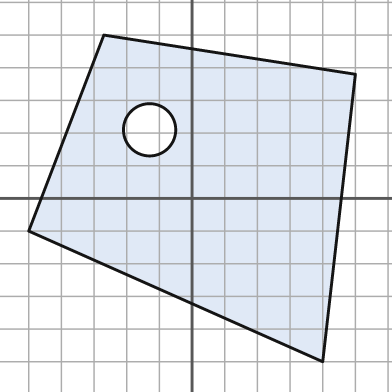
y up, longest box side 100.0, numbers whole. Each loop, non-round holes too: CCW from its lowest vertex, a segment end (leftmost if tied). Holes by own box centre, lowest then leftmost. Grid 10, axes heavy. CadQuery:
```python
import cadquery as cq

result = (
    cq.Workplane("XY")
    .moveTo(40.0, -50.0)
    .lineTo(50.0, 38.0)
    .lineTo(-27.0, 50.0)
    .lineTo(-50.0, -10.0)
    .close()
    .moveTo(-13.0, 21.0)
    .circle(8.0)
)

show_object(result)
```